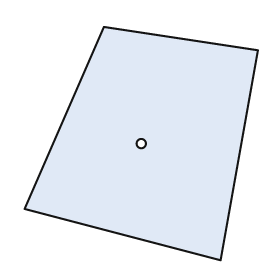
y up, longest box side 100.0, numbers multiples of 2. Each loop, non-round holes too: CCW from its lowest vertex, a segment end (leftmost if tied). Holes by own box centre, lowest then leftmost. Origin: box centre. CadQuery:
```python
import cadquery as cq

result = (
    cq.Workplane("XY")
    .moveTo(34.0, -50.0)
    .lineTo(50.0, 40.0)
    .lineTo(-16.0, 50.0)
    .lineTo(-50.0, -28.0)
    .close()
    .moveTo(0.0, 0.0)
    .circle(2.0)
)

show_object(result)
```